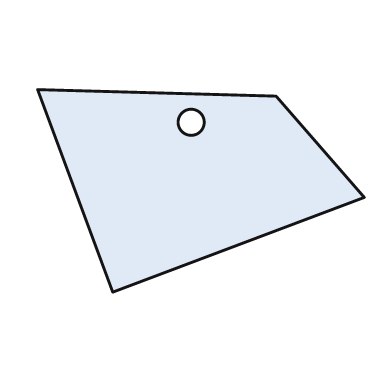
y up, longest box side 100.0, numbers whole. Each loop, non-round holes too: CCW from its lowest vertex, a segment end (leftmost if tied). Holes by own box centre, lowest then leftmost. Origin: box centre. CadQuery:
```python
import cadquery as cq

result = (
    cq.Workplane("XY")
    .moveTo(-27.0, -31.0)
    .lineTo(50.0, -2.0)
    .lineTo(23.0, 29.0)
    .lineTo(-50.0, 31.0)
    .close()
    .moveTo(-3.0, 21.0)
    .circle(4.0)
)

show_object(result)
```